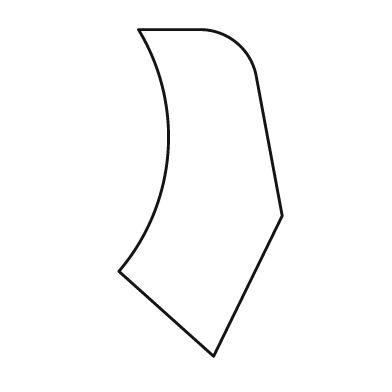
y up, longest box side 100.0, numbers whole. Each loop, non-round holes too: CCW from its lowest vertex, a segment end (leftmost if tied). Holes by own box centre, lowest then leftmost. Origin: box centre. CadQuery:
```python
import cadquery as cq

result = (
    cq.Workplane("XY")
    .moveTo(4.0, -50.0)
    .lineTo(25.0, -7.0)
    .lineTo(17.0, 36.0)
    .threePointArc((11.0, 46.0), (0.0, 50.0))
    .lineTo(-19.0, 50.0)
    .threePointArc((-10.0, 12.0), (-25.0, -24.0))
    .close()
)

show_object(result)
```